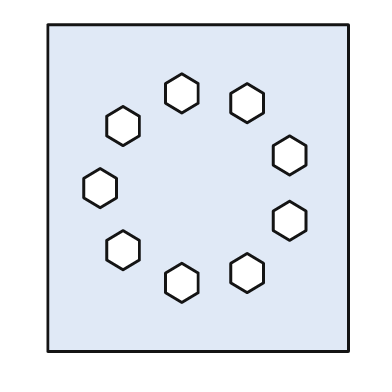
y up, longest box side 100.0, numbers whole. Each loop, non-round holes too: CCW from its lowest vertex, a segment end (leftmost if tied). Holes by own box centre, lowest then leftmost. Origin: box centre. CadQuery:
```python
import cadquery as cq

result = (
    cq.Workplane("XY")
    .moveTo(-46.0, -50.0)
    .lineTo(46.0, -50.0)
    .lineTo(46.0, 50.0)
    .lineTo(-46.0, 50.0)
    .close()
    .moveTo(-5.0, -35.0)
    .lineTo(0.0, -32.0)
    .lineTo(0.0, -26.0)
    .lineTo(-5.0, -23.0)
    .lineTo(-10.0, -26.0)
    .lineTo(-10.0, -32.0)
    .close()
    .moveTo(15.0, -32.0)
    .lineTo(20.0, -29.0)
    .lineTo(20.0, -23.0)
    .lineTo(15.0, -20.0)
    .lineTo(10.0, -23.0)
    .lineTo(10.0, -29.0)
    .close()
    .moveTo(-23.0, -25.0)
    .lineTo(-18.0, -22.0)
    .lineTo(-18.0, -16.0)
    .lineTo(-23.0, -13.0)
    .lineTo(-28.0, -16.0)
    .lineTo(-28.0, -22.0)
    .close()
    .moveTo(28.0, -16.0)
    .lineTo(33.0, -13.0)
    .lineTo(33.0, -7.0)
    .lineTo(28.0, -4.0)
    .lineTo(23.0, -7.0)
    .lineTo(23.0, -13.0)
    .close()
    .moveTo(-30.0, -6.0)
    .lineTo(-25.0, -3.0)
    .lineTo(-25.0, 3.0)
    .lineTo(-30.0, 6.0)
    .lineTo(-35.0, 3.0)
    .lineTo(-35.0, -3.0)
    .close()
    .moveTo(28.0, 4.0)
    .lineTo(33.0, 7.0)
    .lineTo(33.0, 13.0)
    .lineTo(28.0, 16.0)
    .lineTo(23.0, 13.0)
    .lineTo(23.0, 7.0)
    .close()
    .moveTo(-23.0, 13.0)
    .lineTo(-18.0, 16.0)
    .lineTo(-18.0, 22.0)
    .lineTo(-23.0, 25.0)
    .lineTo(-28.0, 22.0)
    .lineTo(-28.0, 16.0)
    .close()
    .moveTo(15.0, 20.0)
    .lineTo(20.0, 23.0)
    .lineTo(20.0, 29.0)
    .lineTo(15.0, 32.0)
    .lineTo(10.0, 29.0)
    .lineTo(10.0, 23.0)
    .close()
    .moveTo(-5.0, 23.0)
    .lineTo(0.0, 26.0)
    .lineTo(0.0, 32.0)
    .lineTo(-5.0, 35.0)
    .lineTo(-10.0, 32.0)
    .lineTo(-10.0, 26.0)
    .close()
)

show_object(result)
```